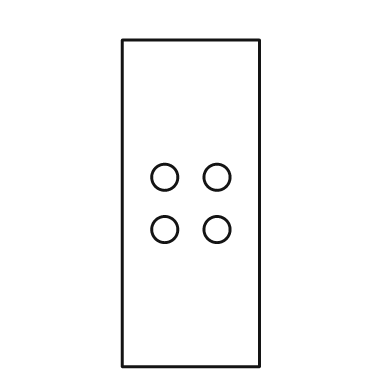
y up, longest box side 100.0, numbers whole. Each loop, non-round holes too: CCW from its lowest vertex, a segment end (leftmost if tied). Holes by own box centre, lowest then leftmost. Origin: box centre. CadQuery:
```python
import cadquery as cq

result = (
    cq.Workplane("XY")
    .moveTo(-21.0, -50.0)
    .lineTo(21.0, -50.0)
    .lineTo(21.0, 50.0)
    .lineTo(-21.0, 50.0)
    .close()
    .moveTo(-8.0, -8.0)
    .circle(4.0)
    .moveTo(8.0, -8.0)
    .circle(4.0)
    .moveTo(-8.0, 8.0)
    .circle(4.0)
    .moveTo(8.0, 8.0)
    .circle(4.0)
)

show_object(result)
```